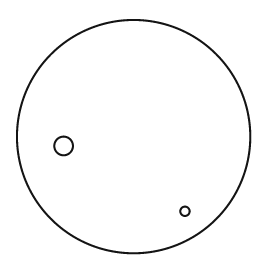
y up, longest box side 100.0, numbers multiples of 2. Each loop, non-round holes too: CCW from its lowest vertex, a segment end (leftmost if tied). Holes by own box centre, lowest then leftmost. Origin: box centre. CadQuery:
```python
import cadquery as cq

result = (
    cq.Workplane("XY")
    .moveTo(0.0, 0.0)
    .circle(50.0)
    .moveTo(22.0, -32.0)
    .circle(2.0)
    .moveTo(-30.0, -4.0)
    .circle(4.0)
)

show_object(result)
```